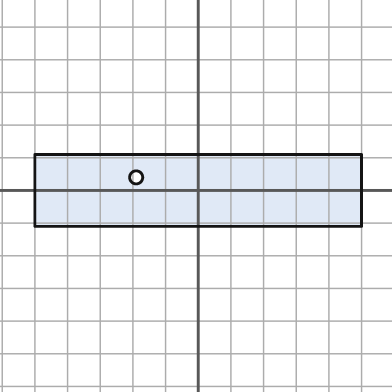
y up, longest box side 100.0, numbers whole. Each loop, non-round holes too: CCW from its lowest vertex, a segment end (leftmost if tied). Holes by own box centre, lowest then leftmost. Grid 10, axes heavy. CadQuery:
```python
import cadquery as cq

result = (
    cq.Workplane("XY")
    .moveTo(-50.0, -11.0)
    .lineTo(50.0, -11.0)
    .lineTo(50.0, 11.0)
    .lineTo(-50.0, 11.0)
    .close()
    .moveTo(-19.0, 4.0)
    .circle(2.0)
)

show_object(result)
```